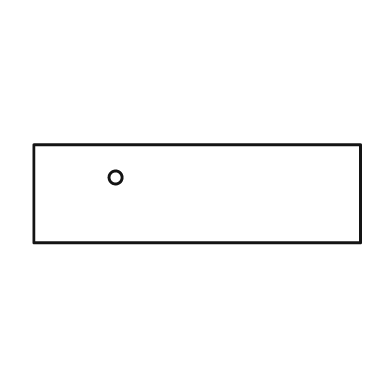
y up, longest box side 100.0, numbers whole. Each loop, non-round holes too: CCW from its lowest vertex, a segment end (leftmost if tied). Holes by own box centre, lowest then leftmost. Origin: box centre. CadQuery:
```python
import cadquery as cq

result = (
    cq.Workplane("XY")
    .moveTo(-50.0, -15.0)
    .lineTo(50.0, -15.0)
    .lineTo(50.0, 15.0)
    .lineTo(-50.0, 15.0)
    .close()
    .moveTo(-25.0, 5.0)
    .circle(2.0)
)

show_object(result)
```